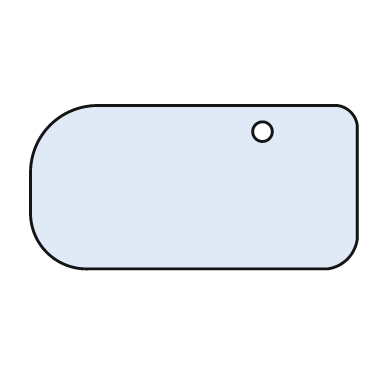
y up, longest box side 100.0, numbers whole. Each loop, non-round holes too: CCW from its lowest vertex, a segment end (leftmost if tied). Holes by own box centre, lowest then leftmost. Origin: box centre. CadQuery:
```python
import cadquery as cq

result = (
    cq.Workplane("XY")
    .moveTo(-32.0, -25.0)
    .lineTo(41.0, -25.0)
    .threePointArc((47.0, -22.0), (50.0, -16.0))
    .lineTo(50.0, 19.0)
    .threePointArc((48.0, 23.0), (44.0, 25.0))
    .lineTo(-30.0, 25.0)
    .threePointArc((-44.0, 19.0), (-50.0, 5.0))
    .lineTo(-50.0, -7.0)
    .threePointArc((-45.0, -20.0), (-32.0, -25.0))
    .close()
    .moveTo(21.0, 17.0)
    .circle(3.0)
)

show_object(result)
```